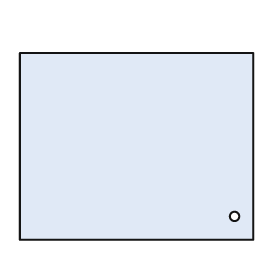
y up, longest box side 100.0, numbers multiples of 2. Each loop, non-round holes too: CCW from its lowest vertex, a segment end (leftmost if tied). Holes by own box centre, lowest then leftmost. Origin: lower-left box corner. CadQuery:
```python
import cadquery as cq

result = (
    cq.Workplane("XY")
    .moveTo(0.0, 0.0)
    .lineTo(100.0, 0.0)
    .lineTo(100.0, 80.0)
    .lineTo(0.0, 80.0)
    .close()
    .moveTo(92.0, 10.0)
    .circle(2.0)
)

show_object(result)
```